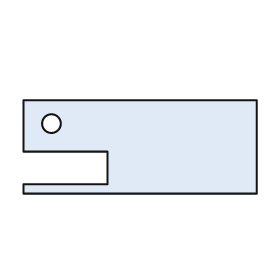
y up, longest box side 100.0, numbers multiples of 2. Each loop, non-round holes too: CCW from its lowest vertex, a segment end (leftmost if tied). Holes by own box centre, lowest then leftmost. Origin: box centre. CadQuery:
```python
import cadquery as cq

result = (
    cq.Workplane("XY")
    .moveTo(-50.0, -20.0)
    .lineTo(50.0, -20.0)
    .lineTo(50.0, 20.0)
    .lineTo(-50.0, 20.0)
    .lineTo(-50.0, -2.0)
    .lineTo(-14.0, -2.0)
    .lineTo(-14.0, -16.0)
    .lineTo(-50.0, -16.0)
    .close()
    .moveTo(-38.0, 10.0)
    .circle(4.0)
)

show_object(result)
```